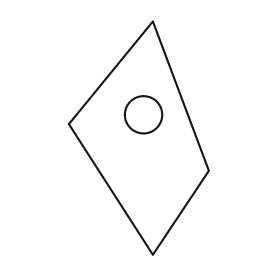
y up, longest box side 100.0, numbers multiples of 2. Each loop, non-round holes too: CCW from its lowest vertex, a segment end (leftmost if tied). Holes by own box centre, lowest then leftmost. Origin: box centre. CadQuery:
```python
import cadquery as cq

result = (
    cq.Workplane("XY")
    .moveTo(6.0, -50.0)
    .lineTo(30.0, -14.0)
    .lineTo(6.0, 50.0)
    .lineTo(-30.0, 6.0)
    .close()
    .moveTo(2.0, 10.0)
    .circle(8.0)
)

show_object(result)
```